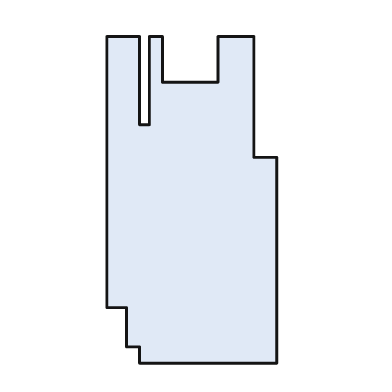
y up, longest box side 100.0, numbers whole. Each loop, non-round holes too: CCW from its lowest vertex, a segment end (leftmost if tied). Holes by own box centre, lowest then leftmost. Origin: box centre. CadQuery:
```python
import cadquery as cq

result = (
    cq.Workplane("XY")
    .moveTo(-16.0, -50.0)
    .lineTo(26.0, -50.0)
    .lineTo(26.0, 13.0)
    .lineTo(19.0, 13.0)
    .lineTo(19.0, 50.0)
    .lineTo(8.0, 50.0)
    .lineTo(8.0, 36.0)
    .lineTo(-9.0, 36.0)
    .lineTo(-9.0, 50.0)
    .lineTo(-13.0, 50.0)
    .lineTo(-13.0, 23.0)
    .lineTo(-16.0, 23.0)
    .lineTo(-16.0, 50.0)
    .lineTo(-26.0, 50.0)
    .lineTo(-26.0, -33.0)
    .lineTo(-20.0, -33.0)
    .lineTo(-20.0, -45.0)
    .lineTo(-16.0, -45.0)
    .close()
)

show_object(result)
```